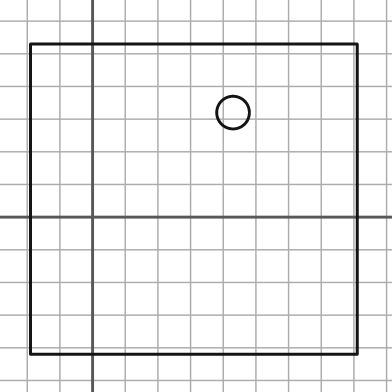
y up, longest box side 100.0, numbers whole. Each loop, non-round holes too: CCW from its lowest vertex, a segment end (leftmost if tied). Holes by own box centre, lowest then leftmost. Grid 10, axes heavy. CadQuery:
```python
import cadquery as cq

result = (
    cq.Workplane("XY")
    .moveTo(-19.0, -42.0)
    .lineTo(81.0, -42.0)
    .lineTo(81.0, 53.0)
    .lineTo(-19.0, 53.0)
    .close()
    .moveTo(43.0, 32.0)
    .circle(5.0)
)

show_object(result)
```